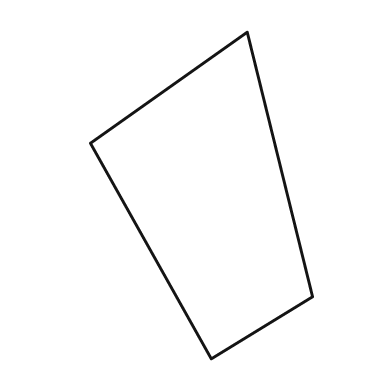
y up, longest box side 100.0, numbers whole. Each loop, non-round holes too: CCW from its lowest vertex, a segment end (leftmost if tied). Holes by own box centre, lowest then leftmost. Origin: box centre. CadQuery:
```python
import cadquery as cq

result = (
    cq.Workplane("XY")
    .moveTo(3.0, -50.0)
    .lineTo(34.0, -31.0)
    .lineTo(14.0, 50.0)
    .lineTo(-34.0, 16.0)
    .close()
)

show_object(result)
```